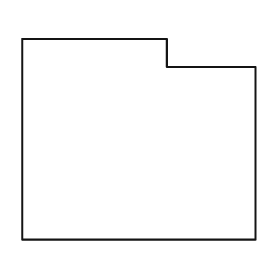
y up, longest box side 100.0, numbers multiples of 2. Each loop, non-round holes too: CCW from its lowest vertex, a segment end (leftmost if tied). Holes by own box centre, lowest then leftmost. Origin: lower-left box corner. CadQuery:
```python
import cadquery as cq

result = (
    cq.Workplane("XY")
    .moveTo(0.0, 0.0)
    .lineTo(100.0, 0.0)
    .lineTo(100.0, 74.0)
    .lineTo(62.0, 74.0)
    .lineTo(62.0, 86.0)
    .lineTo(0.0, 86.0)
    .close()
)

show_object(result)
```